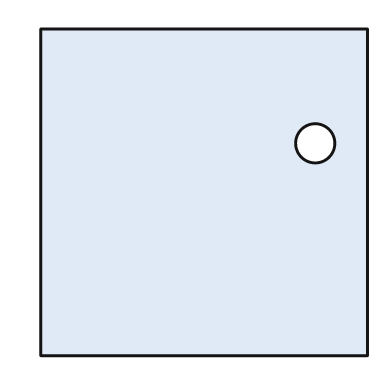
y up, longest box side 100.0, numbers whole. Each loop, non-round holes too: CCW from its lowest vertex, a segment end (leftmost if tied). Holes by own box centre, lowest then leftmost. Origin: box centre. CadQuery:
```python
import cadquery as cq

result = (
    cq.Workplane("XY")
    .moveTo(-50.0, -50.0)
    .lineTo(50.0, -50.0)
    .lineTo(50.0, 50.0)
    .lineTo(-50.0, 50.0)
    .close()
    .moveTo(34.0, 15.0)
    .circle(6.0)
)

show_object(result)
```